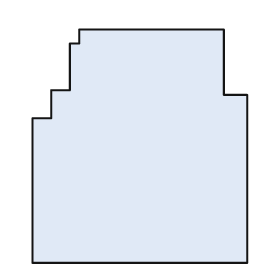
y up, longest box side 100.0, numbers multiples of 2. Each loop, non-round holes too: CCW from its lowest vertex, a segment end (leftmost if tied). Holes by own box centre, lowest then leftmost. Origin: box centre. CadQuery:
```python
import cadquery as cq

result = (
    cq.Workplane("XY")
    .moveTo(-46.0, -50.0)
    .lineTo(46.0, -50.0)
    .lineTo(46.0, 22.0)
    .lineTo(36.0, 22.0)
    .lineTo(36.0, 50.0)
    .lineTo(-26.0, 50.0)
    .lineTo(-26.0, 44.0)
    .lineTo(-30.0, 44.0)
    .lineTo(-30.0, 24.0)
    .lineTo(-38.0, 24.0)
    .lineTo(-38.0, 12.0)
    .lineTo(-46.0, 12.0)
    .close()
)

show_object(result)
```